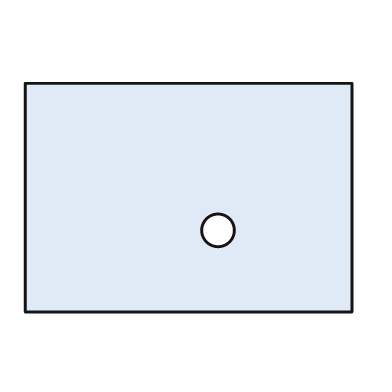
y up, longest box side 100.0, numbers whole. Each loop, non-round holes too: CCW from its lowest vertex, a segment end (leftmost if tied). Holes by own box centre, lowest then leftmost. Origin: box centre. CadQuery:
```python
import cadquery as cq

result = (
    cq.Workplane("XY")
    .moveTo(-50.0, -35.0)
    .lineTo(50.0, -35.0)
    .lineTo(50.0, 35.0)
    .lineTo(-50.0, 35.0)
    .close()
    .moveTo(9.0, -10.0)
    .circle(5.0)
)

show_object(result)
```